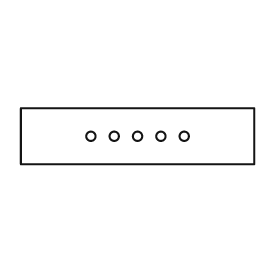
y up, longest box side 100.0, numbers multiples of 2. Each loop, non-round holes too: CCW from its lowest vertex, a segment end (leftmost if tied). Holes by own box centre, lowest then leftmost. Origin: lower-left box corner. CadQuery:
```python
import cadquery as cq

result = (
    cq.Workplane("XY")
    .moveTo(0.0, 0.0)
    .lineTo(100.0, 0.0)
    .lineTo(100.0, 24.0)
    .lineTo(0.0, 24.0)
    .close()
    .moveTo(30.0, 12.0)
    .circle(2.0)
    .moveTo(40.0, 12.0)
    .circle(2.0)
    .moveTo(50.0, 12.0)
    .circle(2.0)
    .moveTo(60.0, 12.0)
    .circle(2.0)
    .moveTo(70.0, 12.0)
    .circle(2.0)
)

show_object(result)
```